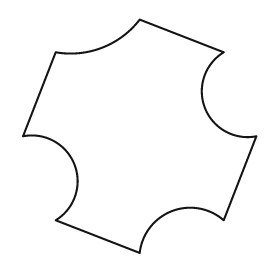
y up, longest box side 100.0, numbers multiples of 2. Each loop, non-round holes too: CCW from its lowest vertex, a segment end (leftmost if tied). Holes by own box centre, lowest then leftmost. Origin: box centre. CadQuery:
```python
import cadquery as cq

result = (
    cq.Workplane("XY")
    .moveTo(0.0, -50.0)
    .threePointArc((14.0, -32.0), (36.0, -36.0))
    .lineTo(50.0, 0.0)
    .threePointArc((28.0, 12.0), (36.0, 36.0))
    .lineTo(0.0, 50.0)
    .threePointArc((-16.0, 38.0), (-36.0, 36.0))
    .lineTo(-50.0, 0.0)
    .threePointArc((-28.0, -12.0), (-36.0, -36.0))
    .close()
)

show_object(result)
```